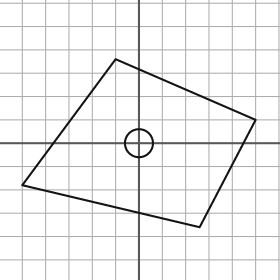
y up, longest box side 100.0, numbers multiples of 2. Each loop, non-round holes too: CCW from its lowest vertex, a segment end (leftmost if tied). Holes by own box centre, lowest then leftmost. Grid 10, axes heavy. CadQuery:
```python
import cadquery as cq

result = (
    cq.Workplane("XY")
    .moveTo(26.0, -36.0)
    .lineTo(50.0, 10.0)
    .lineTo(-10.0, 36.0)
    .lineTo(-50.0, -18.0)
    .close()
    .moveTo(0.0, 0.0)
    .circle(6.0)
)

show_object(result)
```